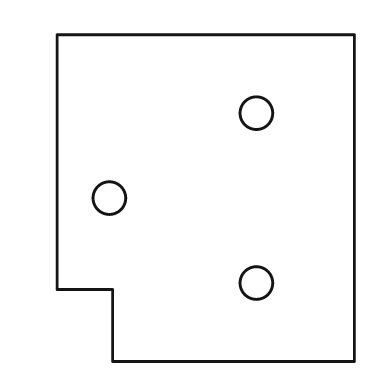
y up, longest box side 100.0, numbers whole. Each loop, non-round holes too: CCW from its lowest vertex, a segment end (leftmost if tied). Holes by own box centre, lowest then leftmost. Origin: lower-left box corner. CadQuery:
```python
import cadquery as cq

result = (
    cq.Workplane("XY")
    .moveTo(17.0, 0.0)
    .lineTo(91.0, 0.0)
    .lineTo(91.0, 100.0)
    .lineTo(0.0, 100.0)
    .lineTo(0.0, 22.0)
    .lineTo(17.0, 22.0)
    .close()
    .moveTo(61.0, 24.0)
    .circle(5.0)
    .moveTo(16.0, 50.0)
    .circle(5.0)
    .moveTo(61.0, 76.0)
    .circle(5.0)
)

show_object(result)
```